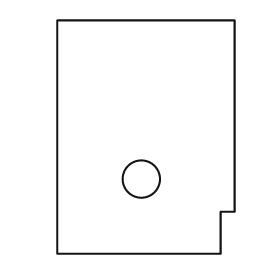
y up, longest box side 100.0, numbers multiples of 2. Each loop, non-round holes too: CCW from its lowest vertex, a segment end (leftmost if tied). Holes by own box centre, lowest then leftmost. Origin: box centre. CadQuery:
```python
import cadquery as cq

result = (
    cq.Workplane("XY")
    .moveTo(-38.0, -50.0)
    .lineTo(32.0, -50.0)
    .lineTo(32.0, -32.0)
    .lineTo(38.0, -32.0)
    .lineTo(38.0, 50.0)
    .lineTo(-38.0, 50.0)
    .close()
    .moveTo(-2.0, -18.0)
    .circle(8.0)
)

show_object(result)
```